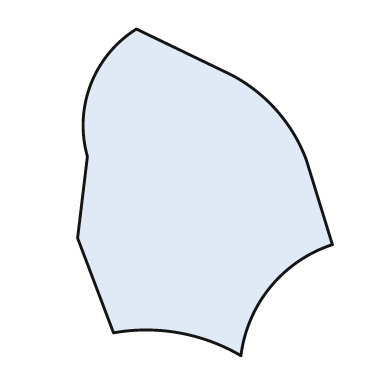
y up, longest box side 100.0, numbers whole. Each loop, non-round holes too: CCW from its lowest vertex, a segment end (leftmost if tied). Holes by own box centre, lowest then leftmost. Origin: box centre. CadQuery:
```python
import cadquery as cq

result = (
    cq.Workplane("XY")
    .moveTo(11.0, -50.0)
    .threePointArc((20.0, -29.0), (39.0, -16.0))
    .lineTo(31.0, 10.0)
    .threePointArc((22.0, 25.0), (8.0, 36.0))
    .lineTo(-21.0, 50.0)
    .threePointArc((-35.0, 33.0), (-36.0, 11.0))
    .lineTo(-39.0, -14.0)
    .lineTo(-28.0, -43.0)
    .threePointArc((-8.0, -43.0), (11.0, -50.0))
    .close()
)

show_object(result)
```